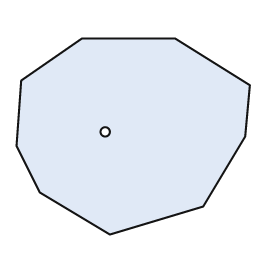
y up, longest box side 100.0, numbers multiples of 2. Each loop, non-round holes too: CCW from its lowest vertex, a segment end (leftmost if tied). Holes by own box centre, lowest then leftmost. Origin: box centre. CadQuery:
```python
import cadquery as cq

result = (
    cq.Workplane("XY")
    .moveTo(-10.0, -42.0)
    .lineTo(30.0, -30.0)
    .lineTo(48.0, 0.0)
    .lineTo(50.0, 22.0)
    .lineTo(18.0, 42.0)
    .lineTo(-22.0, 42.0)
    .lineTo(-48.0, 24.0)
    .lineTo(-50.0, -4.0)
    .lineTo(-40.0, -24.0)
    .close()
    .moveTo(-12.0, 2.0)
    .circle(2.0)
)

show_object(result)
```